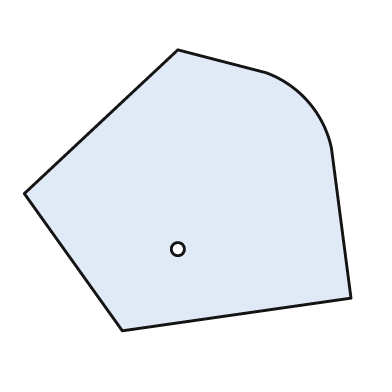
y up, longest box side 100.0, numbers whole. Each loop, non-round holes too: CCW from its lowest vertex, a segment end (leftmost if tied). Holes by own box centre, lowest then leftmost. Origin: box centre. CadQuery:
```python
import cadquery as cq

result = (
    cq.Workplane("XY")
    .moveTo(-20.0, -43.0)
    .lineTo(50.0, -33.0)
    .lineTo(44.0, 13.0)
    .threePointArc((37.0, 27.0), (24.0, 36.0))
    .lineTo(-3.0, 43.0)
    .lineTo(-50.0, -1.0)
    .close()
    .moveTo(-3.0, -18.0)
    .circle(2.0)
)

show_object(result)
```